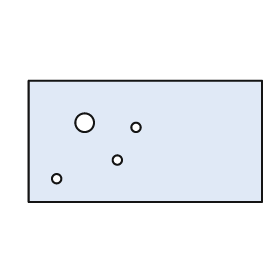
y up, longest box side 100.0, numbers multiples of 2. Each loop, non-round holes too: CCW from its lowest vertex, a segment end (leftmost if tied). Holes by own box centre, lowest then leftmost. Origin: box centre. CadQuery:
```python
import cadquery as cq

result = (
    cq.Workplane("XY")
    .moveTo(-50.0, -26.0)
    .lineTo(50.0, -26.0)
    .lineTo(50.0, 26.0)
    .lineTo(-50.0, 26.0)
    .close()
    .moveTo(-38.0, -16.0)
    .circle(2.0)
    .moveTo(-12.0, -8.0)
    .circle(2.0)
    .moveTo(-4.0, 6.0)
    .circle(2.0)
    .moveTo(-26.0, 8.0)
    .circle(4.0)
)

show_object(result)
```